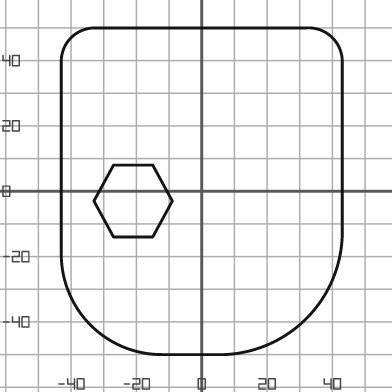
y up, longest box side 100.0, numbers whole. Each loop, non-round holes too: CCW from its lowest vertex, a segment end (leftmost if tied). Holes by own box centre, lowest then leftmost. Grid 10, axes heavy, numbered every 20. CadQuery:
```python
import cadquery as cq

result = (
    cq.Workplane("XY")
    .moveTo(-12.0, -50.0)
    .lineTo(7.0, -50.0)
    .threePointArc((32.0, -39.0), (43.0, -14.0))
    .lineTo(43.0, 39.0)
    .threePointArc((40.0, 47.0), (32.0, 50.0))
    .lineTo(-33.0, 50.0)
    .threePointArc((-40.0, 47.0), (-43.0, 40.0))
    .lineTo(-43.0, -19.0)
    .threePointArc((-34.0, -41.0), (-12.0, -50.0))
    .close()
    .moveTo(-27.0, -14.0)
    .lineTo(-15.0, -14.0)
    .lineTo(-9.0, -3.0)
    .lineTo(-15.0, 8.0)
    .lineTo(-27.0, 8.0)
    .lineTo(-33.0, -3.0)
    .close()
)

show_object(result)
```